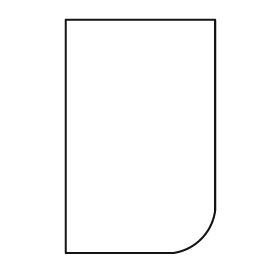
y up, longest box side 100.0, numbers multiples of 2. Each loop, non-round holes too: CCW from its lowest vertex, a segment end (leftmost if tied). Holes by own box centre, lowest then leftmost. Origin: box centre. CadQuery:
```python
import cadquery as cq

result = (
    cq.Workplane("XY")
    .moveTo(-32.0, -50.0)
    .lineTo(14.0, -50.0)
    .threePointArc((26.0, -44.0), (32.0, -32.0))
    .lineTo(32.0, 50.0)
    .lineTo(-32.0, 50.0)
    .close()
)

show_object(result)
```